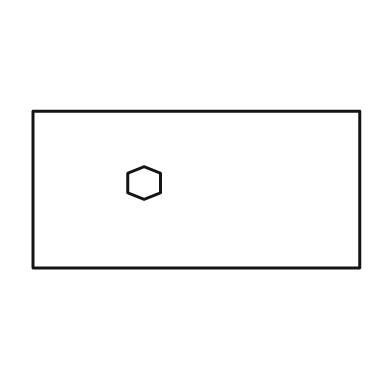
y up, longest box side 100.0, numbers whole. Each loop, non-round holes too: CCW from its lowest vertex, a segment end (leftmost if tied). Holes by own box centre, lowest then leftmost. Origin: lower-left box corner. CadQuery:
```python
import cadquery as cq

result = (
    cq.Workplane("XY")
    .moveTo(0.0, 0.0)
    .lineTo(100.0, 0.0)
    .lineTo(100.0, 48.0)
    .lineTo(0.0, 48.0)
    .close()
    .moveTo(34.0, 21.0)
    .lineTo(39.0, 23.0)
    .lineTo(39.0, 29.0)
    .lineTo(34.0, 31.0)
    .lineTo(29.0, 29.0)
    .lineTo(29.0, 23.0)
    .close()
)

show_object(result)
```